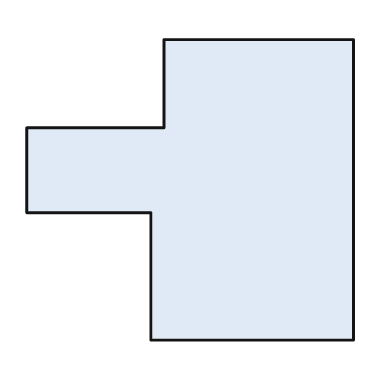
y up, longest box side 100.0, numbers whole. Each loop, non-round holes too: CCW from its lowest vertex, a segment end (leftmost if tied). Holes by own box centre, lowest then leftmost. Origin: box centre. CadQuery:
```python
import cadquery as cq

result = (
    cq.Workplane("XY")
    .moveTo(-12.0, -46.0)
    .lineTo(50.0, -46.0)
    .lineTo(50.0, 46.0)
    .lineTo(-8.0, 46.0)
    .lineTo(-8.0, 19.0)
    .lineTo(-50.0, 19.0)
    .lineTo(-50.0, -7.0)
    .lineTo(-12.0, -7.0)
    .close()
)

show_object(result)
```